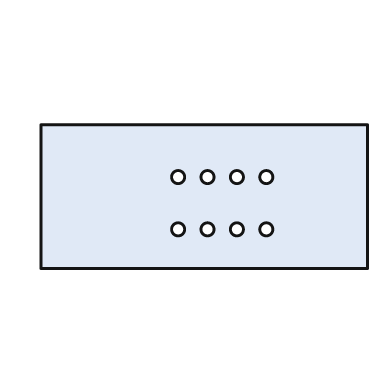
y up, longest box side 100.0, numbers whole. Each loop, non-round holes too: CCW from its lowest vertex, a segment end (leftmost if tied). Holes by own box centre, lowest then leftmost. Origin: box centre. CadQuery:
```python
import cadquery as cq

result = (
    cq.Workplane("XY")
    .moveTo(-50.0, -22.0)
    .lineTo(50.0, -22.0)
    .lineTo(50.0, 22.0)
    .lineTo(-50.0, 22.0)
    .close()
    .moveTo(-8.0, -10.0)
    .circle(2.0)
    .moveTo(1.0, -10.0)
    .circle(2.0)
    .moveTo(10.0, -10.0)
    .circle(2.0)
    .moveTo(19.0, -10.0)
    .circle(2.0)
    .moveTo(-8.0, 6.0)
    .circle(2.0)
    .moveTo(1.0, 6.0)
    .circle(2.0)
    .moveTo(10.0, 6.0)
    .circle(2.0)
    .moveTo(19.0, 6.0)
    .circle(2.0)
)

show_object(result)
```